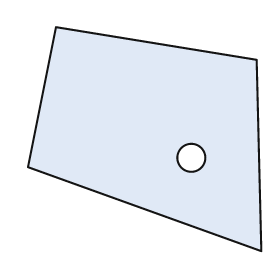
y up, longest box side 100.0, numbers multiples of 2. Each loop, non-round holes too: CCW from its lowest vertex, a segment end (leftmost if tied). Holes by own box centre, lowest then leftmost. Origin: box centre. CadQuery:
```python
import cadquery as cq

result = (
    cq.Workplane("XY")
    .moveTo(50.0, -48.0)
    .lineTo(48.0, 34.0)
    .lineTo(-38.0, 48.0)
    .lineTo(-50.0, -12.0)
    .close()
    .moveTo(20.0, -8.0)
    .circle(6.0)
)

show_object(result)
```